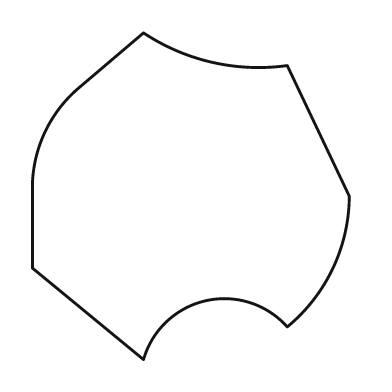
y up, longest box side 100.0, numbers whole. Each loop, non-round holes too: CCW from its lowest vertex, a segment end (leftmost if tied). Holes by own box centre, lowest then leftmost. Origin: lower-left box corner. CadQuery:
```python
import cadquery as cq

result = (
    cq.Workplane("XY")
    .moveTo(34.0, 0.0)
    .threePointArc((53.0, 18.0), (78.0, 10.0))
    .threePointArc((92.0, 28.0), (97.0, 50.0))
    .lineTo(78.0, 90.0)
    .threePointArc((55.0, 91.0), (34.0, 100.0))
    .lineTo(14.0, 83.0)
    .threePointArc((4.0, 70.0), (0.0, 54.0))
    .lineTo(0.0, 28.0)
    .close()
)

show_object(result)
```